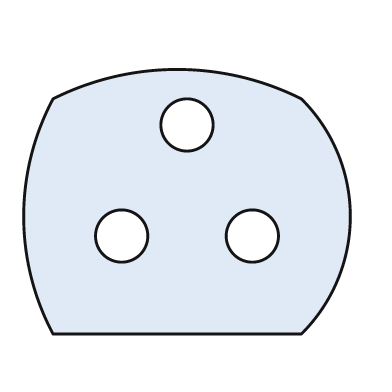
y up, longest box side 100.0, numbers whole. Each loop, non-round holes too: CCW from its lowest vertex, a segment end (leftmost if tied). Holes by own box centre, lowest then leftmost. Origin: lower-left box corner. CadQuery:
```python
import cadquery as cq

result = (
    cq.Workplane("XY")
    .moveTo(9.0, 0.0)
    .lineTo(85.0, 0.0)
    .threePointArc((100.0, 36.0), (85.0, 72.0))
    .threePointArc((47.0, 81.0), (9.0, 72.0))
    .threePointArc((0.0, 36.0), (9.0, 0.0))
    .close()
    .moveTo(30.0, 30.0)
    .circle(8.0)
    .moveTo(70.0, 30.0)
    .circle(8.0)
    .moveTo(50.0, 64.0)
    .circle(8.0)
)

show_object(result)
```